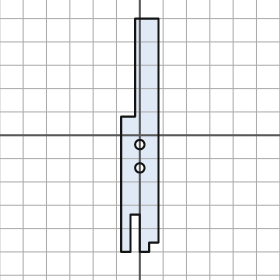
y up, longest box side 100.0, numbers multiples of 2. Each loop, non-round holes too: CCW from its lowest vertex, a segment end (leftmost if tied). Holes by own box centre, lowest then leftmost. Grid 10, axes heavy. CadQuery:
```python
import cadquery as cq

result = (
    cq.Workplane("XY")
    .moveTo(-8.0, -50.0)
    .lineTo(-4.0, -50.0)
    .lineTo(-4.0, -34.0)
    .lineTo(0.0, -34.0)
    .lineTo(0.0, -50.0)
    .lineTo(4.0, -50.0)
    .lineTo(4.0, -46.0)
    .lineTo(8.0, -46.0)
    .lineTo(8.0, 50.0)
    .lineTo(-2.0, 50.0)
    .lineTo(-2.0, 8.0)
    .lineTo(-8.0, 8.0)
    .close()
    .moveTo(0.0, -14.0)
    .circle(2.0)
    .moveTo(0.0, -4.0)
    .circle(2.0)
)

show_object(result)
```